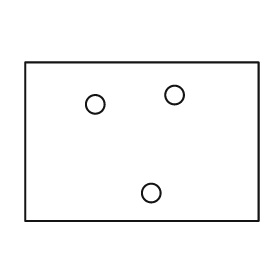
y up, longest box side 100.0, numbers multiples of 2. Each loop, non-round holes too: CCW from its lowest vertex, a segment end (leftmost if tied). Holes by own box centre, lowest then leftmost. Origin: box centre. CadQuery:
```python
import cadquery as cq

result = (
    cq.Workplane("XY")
    .moveTo(-50.0, -34.0)
    .lineTo(50.0, -34.0)
    .lineTo(50.0, 34.0)
    .lineTo(-50.0, 34.0)
    .close()
    .moveTo(4.0, -22.0)
    .circle(4.0)
    .moveTo(-20.0, 16.0)
    .circle(4.0)
    .moveTo(14.0, 20.0)
    .circle(4.0)
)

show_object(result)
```